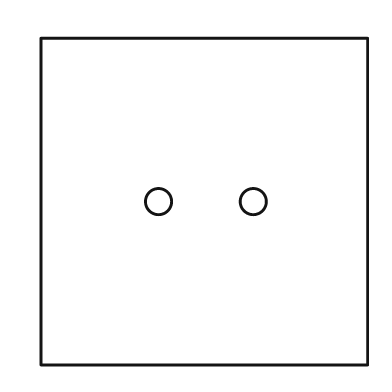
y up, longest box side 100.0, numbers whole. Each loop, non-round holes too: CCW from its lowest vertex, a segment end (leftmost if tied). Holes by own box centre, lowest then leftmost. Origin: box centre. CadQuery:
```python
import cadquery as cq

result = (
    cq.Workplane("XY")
    .moveTo(-50.0, -50.0)
    .lineTo(50.0, -50.0)
    .lineTo(50.0, 50.0)
    .lineTo(-50.0, 50.0)
    .close()
    .moveTo(-14.0, 0.0)
    .circle(4.0)
    .moveTo(15.0, 0.0)
    .circle(4.0)
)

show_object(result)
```